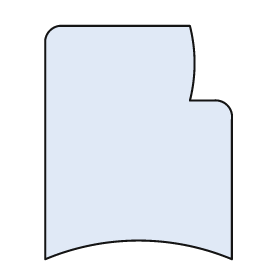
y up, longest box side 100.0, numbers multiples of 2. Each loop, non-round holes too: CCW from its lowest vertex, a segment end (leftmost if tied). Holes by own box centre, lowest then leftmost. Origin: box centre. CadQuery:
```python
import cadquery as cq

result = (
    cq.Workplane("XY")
    .moveTo(-40.0, -50.0)
    .threePointArc((0.0, -42.0), (40.0, -50.0))
    .lineTo(40.0, 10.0)
    .threePointArc((38.0, 16.0), (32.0, 18.0))
    .lineTo(22.0, 18.0)
    .threePointArc((24.0, 34.0), (22.0, 50.0))
    .lineTo(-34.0, 50.0)
    .threePointArc((-38.0, 48.0), (-40.0, 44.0))
    .close()
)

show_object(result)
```